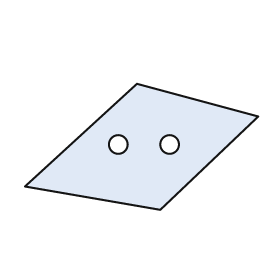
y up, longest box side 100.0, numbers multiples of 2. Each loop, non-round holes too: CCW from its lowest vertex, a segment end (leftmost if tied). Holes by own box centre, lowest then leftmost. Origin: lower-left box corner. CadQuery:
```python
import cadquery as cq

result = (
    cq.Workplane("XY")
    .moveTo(58.0, 0.0)
    .lineTo(100.0, 40.0)
    .lineTo(48.0, 54.0)
    .lineTo(0.0, 10.0)
    .close()
    .moveTo(40.0, 28.0)
    .circle(4.0)
    .moveTo(62.0, 28.0)
    .circle(4.0)
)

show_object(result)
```